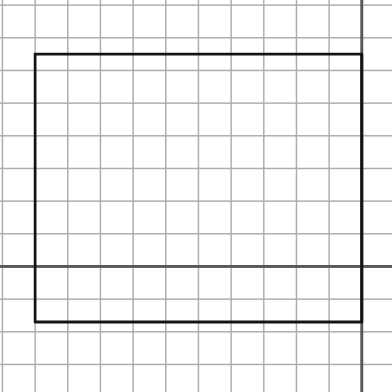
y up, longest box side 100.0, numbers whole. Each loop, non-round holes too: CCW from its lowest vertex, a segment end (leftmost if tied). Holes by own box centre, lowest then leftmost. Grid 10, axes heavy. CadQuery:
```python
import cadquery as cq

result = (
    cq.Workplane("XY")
    .moveTo(-100.0, -17.0)
    .lineTo(0.0, -17.0)
    .lineTo(0.0, 65.0)
    .lineTo(-100.0, 65.0)
    .close()
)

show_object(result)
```